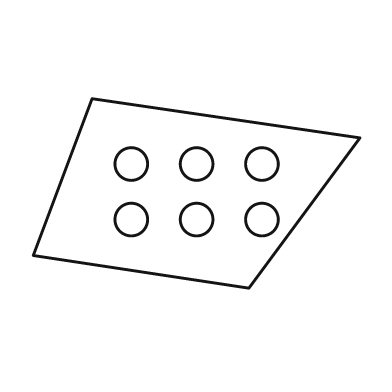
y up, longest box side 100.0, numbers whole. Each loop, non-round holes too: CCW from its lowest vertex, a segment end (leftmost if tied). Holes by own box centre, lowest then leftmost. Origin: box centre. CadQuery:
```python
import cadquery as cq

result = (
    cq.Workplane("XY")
    .moveTo(16.0, -29.0)
    .lineTo(50.0, 17.0)
    .lineTo(-32.0, 29.0)
    .lineTo(-50.0, -19.0)
    .close()
    .moveTo(-20.0, -8.0)
    .circle(5.0)
    .moveTo(0.0, -8.0)
    .circle(5.0)
    .moveTo(20.0, -8.0)
    .circle(5.0)
    .moveTo(-20.0, 9.0)
    .circle(5.0)
    .moveTo(0.0, 9.0)
    .circle(5.0)
    .moveTo(20.0, 9.0)
    .circle(5.0)
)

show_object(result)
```